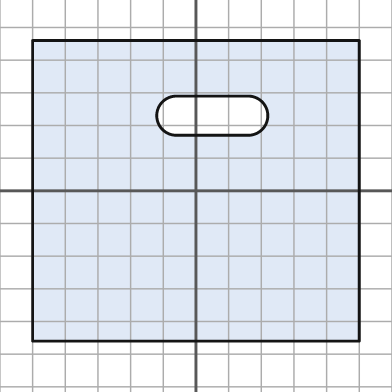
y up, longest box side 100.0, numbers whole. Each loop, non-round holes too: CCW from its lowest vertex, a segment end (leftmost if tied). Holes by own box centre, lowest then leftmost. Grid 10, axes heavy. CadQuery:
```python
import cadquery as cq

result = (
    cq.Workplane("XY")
    .moveTo(-50.0, -46.0)
    .lineTo(50.0, -46.0)
    .lineTo(50.0, 46.0)
    .lineTo(-50.0, 46.0)
    .close()
    .moveTo(-6.0, 17.0)
    .lineTo(16.0, 17.0)
    .threePointArc((22.0, 23.0), (16.0, 29.0))
    .lineTo(-6.0, 29.0)
    .threePointArc((-12.0, 23.0), (-6.0, 17.0))
    .close()
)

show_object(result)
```